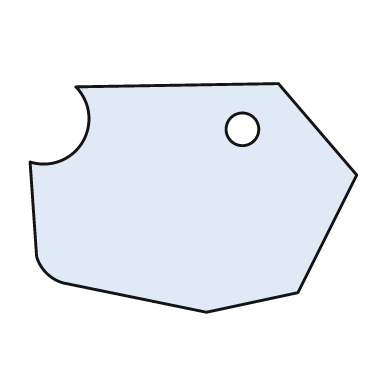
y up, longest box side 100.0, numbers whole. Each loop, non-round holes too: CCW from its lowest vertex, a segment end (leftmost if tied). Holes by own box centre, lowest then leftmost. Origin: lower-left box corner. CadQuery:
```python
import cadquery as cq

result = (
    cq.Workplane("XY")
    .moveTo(54.0, 0.0)
    .lineTo(82.0, 6.0)
    .lineTo(100.0, 42.0)
    .lineTo(76.0, 70.0)
    .lineTo(14.0, 69.0)
    .threePointArc((16.0, 52.0), (0.0, 46.0))
    .lineTo(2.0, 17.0)
    .threePointArc((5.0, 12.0), (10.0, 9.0))
    .close()
    .moveTo(65.0, 56.0)
    .circle(5.0)
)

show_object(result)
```